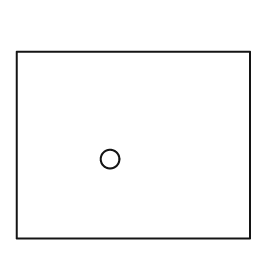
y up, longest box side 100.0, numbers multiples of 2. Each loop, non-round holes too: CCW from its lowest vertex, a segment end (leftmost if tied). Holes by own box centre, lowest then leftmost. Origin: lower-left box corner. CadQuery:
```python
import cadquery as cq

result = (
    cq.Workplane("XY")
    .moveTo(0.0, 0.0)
    .lineTo(100.0, 0.0)
    .lineTo(100.0, 80.0)
    .lineTo(0.0, 80.0)
    .close()
    .moveTo(40.0, 34.0)
    .circle(4.0)
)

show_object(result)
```